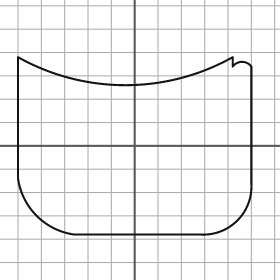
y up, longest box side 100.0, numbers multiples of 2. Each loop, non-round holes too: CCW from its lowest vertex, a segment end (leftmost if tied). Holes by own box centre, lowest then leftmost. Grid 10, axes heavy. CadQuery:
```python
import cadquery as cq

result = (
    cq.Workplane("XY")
    .moveTo(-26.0, -38.0)
    .lineTo(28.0, -38.0)
    .threePointArc((44.0, -32.0), (50.0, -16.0))
    .lineTo(50.0, 34.0)
    .threePointArc((46.0, 36.0), (42.0, 34.0))
    .lineTo(42.0, 38.0)
    .threePointArc((-4.0, 26.0), (-50.0, 38.0))
    .lineTo(-50.0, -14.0)
    .threePointArc((-42.0, -30.0), (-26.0, -38.0))
    .close()
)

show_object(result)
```